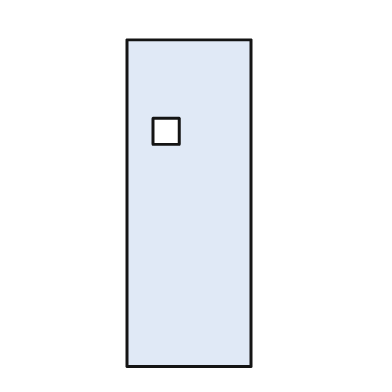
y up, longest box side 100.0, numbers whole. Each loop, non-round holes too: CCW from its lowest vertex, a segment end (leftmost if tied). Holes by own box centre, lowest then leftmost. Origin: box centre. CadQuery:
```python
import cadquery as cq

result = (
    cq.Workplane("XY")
    .moveTo(-19.0, -50.0)
    .lineTo(19.0, -50.0)
    .lineTo(19.0, 50.0)
    .lineTo(-19.0, 50.0)
    .close()
    .moveTo(-11.0, 18.0)
    .lineTo(-3.0, 18.0)
    .lineTo(-3.0, 26.0)
    .lineTo(-11.0, 26.0)
    .close()
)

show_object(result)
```